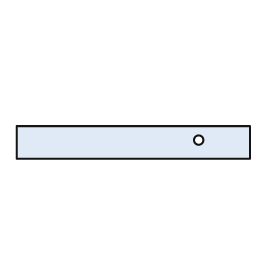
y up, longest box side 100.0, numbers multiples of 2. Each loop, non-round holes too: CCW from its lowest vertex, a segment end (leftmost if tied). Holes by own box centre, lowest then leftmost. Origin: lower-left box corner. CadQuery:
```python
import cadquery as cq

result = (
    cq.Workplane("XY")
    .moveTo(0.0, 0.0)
    .lineTo(100.0, 0.0)
    .lineTo(100.0, 14.0)
    .lineTo(0.0, 14.0)
    .close()
    .moveTo(78.0, 8.0)
    .circle(2.0)
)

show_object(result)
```